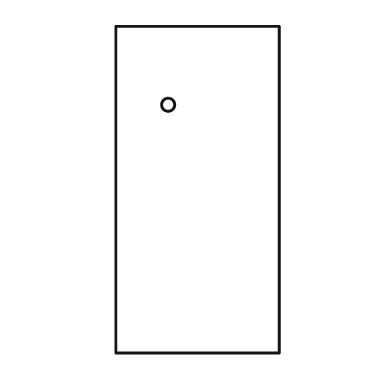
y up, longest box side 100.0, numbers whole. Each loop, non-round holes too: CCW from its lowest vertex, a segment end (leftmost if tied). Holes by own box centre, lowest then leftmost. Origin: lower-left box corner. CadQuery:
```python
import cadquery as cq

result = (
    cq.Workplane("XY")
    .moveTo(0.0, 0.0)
    .lineTo(50.0, 0.0)
    .lineTo(50.0, 100.0)
    .lineTo(0.0, 100.0)
    .close()
    .moveTo(16.0, 76.0)
    .circle(2.0)
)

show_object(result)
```